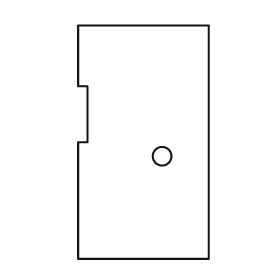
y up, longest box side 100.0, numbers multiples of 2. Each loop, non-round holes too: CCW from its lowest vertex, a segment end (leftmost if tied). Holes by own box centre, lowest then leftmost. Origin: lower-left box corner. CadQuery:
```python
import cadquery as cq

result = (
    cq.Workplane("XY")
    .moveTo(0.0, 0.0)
    .lineTo(56.0, 0.0)
    .lineTo(56.0, 100.0)
    .lineTo(0.0, 100.0)
    .lineTo(0.0, 74.0)
    .lineTo(4.0, 74.0)
    .lineTo(4.0, 50.0)
    .lineTo(0.0, 50.0)
    .close()
    .moveTo(36.0, 44.0)
    .circle(4.0)
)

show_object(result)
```